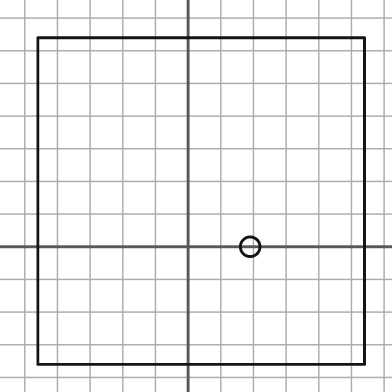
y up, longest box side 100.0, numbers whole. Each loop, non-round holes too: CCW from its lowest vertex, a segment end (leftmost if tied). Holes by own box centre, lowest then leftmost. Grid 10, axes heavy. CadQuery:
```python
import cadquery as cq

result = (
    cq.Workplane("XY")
    .moveTo(-46.0, -36.0)
    .lineTo(54.0, -36.0)
    .lineTo(54.0, 64.0)
    .lineTo(-46.0, 64.0)
    .close()
    .moveTo(19.0, 0.0)
    .circle(3.0)
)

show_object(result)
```